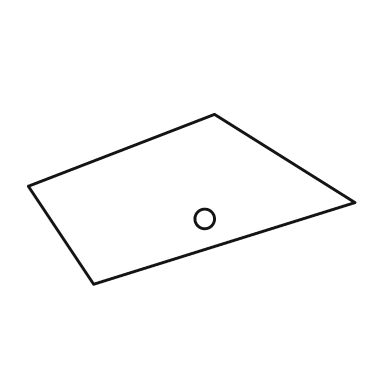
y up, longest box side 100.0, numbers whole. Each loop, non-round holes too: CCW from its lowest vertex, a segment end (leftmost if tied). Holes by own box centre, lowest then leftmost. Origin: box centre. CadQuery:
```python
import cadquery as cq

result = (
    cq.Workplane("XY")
    .moveTo(-30.0, -26.0)
    .lineTo(50.0, -1.0)
    .lineTo(7.0, 26.0)
    .lineTo(-50.0, 4.0)
    .close()
    .moveTo(4.0, -6.0)
    .circle(3.0)
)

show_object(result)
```